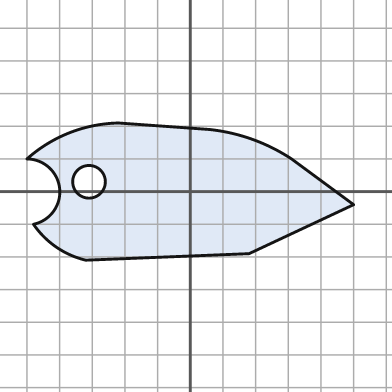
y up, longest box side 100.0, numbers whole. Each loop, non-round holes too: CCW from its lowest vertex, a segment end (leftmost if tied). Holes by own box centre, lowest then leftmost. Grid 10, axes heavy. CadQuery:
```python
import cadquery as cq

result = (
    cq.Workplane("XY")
    .moveTo(-32.0, -21.0)
    .lineTo(18.0, -19.0)
    .lineTo(50.0, -4.0)
    .lineTo(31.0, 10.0)
    .threePointArc((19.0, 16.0), (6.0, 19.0))
    .lineTo(-22.0, 21.0)
    .threePointArc((-37.0, 18.0), (-50.0, 10.0))
    .threePointArc((-40.0, 1.0), (-48.0, -10.0))
    .threePointArc((-41.0, -17.0), (-32.0, -21.0))
    .close()
    .moveTo(-31.0, 3.0)
    .circle(5.0)
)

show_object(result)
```